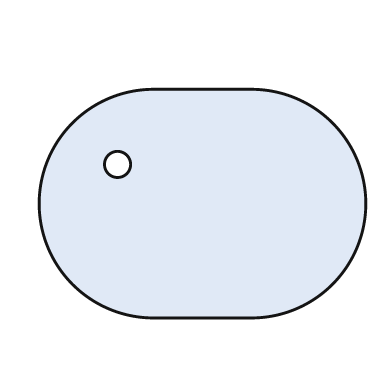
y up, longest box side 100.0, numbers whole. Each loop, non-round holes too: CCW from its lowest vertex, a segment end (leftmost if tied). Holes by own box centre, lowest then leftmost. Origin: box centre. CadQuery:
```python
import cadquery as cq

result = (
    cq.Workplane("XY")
    .moveTo(-15.0, -35.0)
    .lineTo(15.0, -35.0)
    .threePointArc((50.0, 0.0), (15.0, 35.0))
    .lineTo(-15.0, 35.0)
    .threePointArc((-50.0, 0.0), (-15.0, -35.0))
    .close()
    .moveTo(-26.0, 12.0)
    .circle(4.0)
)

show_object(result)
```